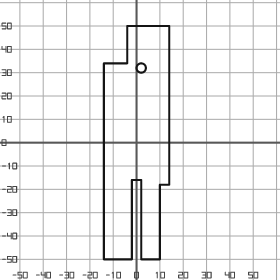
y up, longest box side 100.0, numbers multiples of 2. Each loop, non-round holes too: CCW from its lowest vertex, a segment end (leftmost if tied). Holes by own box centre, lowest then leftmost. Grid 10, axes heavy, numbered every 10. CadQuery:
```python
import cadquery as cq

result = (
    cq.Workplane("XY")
    .moveTo(-14.0, -50.0)
    .lineTo(-2.0, -50.0)
    .lineTo(-2.0, -16.0)
    .lineTo(2.0, -16.0)
    .lineTo(2.0, -50.0)
    .lineTo(10.0, -50.0)
    .lineTo(10.0, -18.0)
    .lineTo(14.0, -18.0)
    .lineTo(14.0, 50.0)
    .lineTo(-4.0, 50.0)
    .lineTo(-4.0, 34.0)
    .lineTo(-14.0, 34.0)
    .close()
    .moveTo(2.0, 32.0)
    .circle(2.0)
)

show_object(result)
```